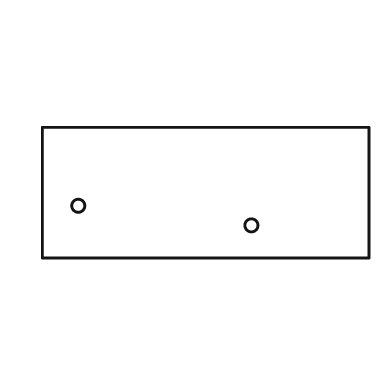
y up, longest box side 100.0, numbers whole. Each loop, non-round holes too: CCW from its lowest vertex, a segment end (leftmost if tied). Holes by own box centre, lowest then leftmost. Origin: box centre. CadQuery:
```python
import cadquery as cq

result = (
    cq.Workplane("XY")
    .moveTo(-50.0, -20.0)
    .lineTo(50.0, -20.0)
    .lineTo(50.0, 20.0)
    .lineTo(-50.0, 20.0)
    .close()
    .moveTo(14.0, -10.0)
    .circle(2.0)
    .moveTo(-39.0, -4.0)
    .circle(2.0)
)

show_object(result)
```